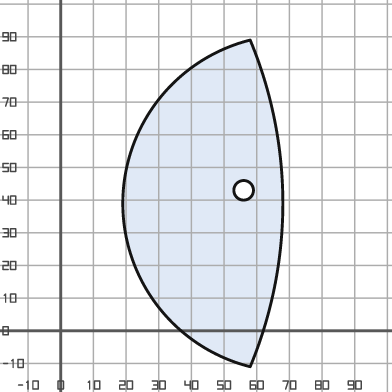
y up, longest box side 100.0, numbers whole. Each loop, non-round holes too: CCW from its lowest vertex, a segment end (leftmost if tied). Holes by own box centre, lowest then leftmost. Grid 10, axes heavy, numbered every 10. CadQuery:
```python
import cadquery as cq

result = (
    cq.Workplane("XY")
    .moveTo(58.0, -11.0)
    .threePointArc((68.0, 39.0), (58.0, 89.0))
    .threePointArc((19.0, 39.0), (58.0, -11.0))
    .close()
    .moveTo(56.0, 43.0)
    .circle(3.0)
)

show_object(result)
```